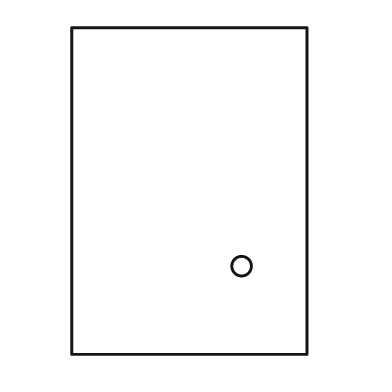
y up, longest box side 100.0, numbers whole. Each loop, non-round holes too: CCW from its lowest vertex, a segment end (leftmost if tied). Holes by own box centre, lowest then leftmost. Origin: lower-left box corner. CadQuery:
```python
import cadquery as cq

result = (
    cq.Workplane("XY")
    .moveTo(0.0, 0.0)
    .lineTo(72.0, 0.0)
    .lineTo(72.0, 100.0)
    .lineTo(0.0, 100.0)
    .close()
    .moveTo(52.0, 27.0)
    .circle(3.0)
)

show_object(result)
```